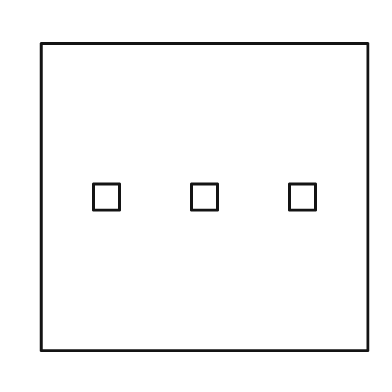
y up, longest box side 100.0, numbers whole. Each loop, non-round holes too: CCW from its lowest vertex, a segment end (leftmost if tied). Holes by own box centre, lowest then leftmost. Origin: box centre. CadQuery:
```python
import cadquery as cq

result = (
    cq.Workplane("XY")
    .moveTo(-50.0, -47.0)
    .lineTo(50.0, -47.0)
    .lineTo(50.0, 47.0)
    .lineTo(-50.0, 47.0)
    .close()
    .moveTo(-34.0, -4.0)
    .lineTo(-26.0, -4.0)
    .lineTo(-26.0, 4.0)
    .lineTo(-34.0, 4.0)
    .close()
    .moveTo(-4.0, -4.0)
    .lineTo(4.0, -4.0)
    .lineTo(4.0, 4.0)
    .lineTo(-4.0, 4.0)
    .close()
    .moveTo(26.0, -4.0)
    .lineTo(34.0, -4.0)
    .lineTo(34.0, 4.0)
    .lineTo(26.0, 4.0)
    .close()
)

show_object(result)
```